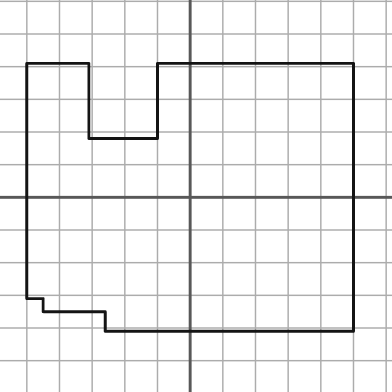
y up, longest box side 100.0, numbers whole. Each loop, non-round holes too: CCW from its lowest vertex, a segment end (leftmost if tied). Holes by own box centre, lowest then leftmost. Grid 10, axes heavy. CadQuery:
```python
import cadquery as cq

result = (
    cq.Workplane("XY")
    .moveTo(-26.0, -41.0)
    .lineTo(50.0, -41.0)
    .lineTo(50.0, 41.0)
    .lineTo(-10.0, 41.0)
    .lineTo(-10.0, 18.0)
    .lineTo(-31.0, 18.0)
    .lineTo(-31.0, 41.0)
    .lineTo(-50.0, 41.0)
    .lineTo(-50.0, -31.0)
    .lineTo(-45.0, -31.0)
    .lineTo(-45.0, -35.0)
    .lineTo(-26.0, -35.0)
    .close()
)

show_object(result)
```